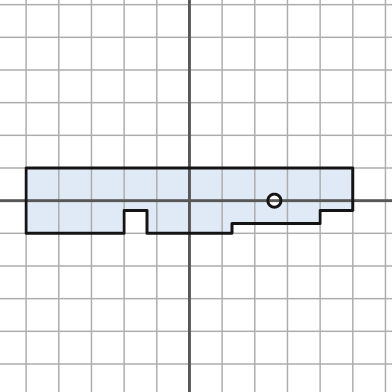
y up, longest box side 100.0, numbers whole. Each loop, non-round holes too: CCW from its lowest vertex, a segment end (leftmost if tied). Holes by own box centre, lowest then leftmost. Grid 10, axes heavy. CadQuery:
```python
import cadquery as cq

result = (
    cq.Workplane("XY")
    .moveTo(-50.0, -10.0)
    .lineTo(-20.0, -10.0)
    .lineTo(-20.0, -3.0)
    .lineTo(-13.0, -3.0)
    .lineTo(-13.0, -10.0)
    .lineTo(13.0, -10.0)
    .lineTo(13.0, -7.0)
    .lineTo(40.0, -7.0)
    .lineTo(40.0, -3.0)
    .lineTo(50.0, -3.0)
    .lineTo(50.0, 10.0)
    .lineTo(-50.0, 10.0)
    .close()
    .moveTo(26.0, 0.0)
    .circle(2.0)
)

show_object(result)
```